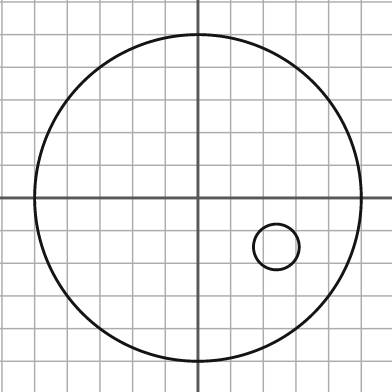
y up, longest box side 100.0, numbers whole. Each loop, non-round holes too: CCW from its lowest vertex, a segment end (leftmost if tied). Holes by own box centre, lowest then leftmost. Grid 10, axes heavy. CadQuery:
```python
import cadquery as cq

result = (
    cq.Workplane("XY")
    .moveTo(0.0, 0.0)
    .circle(50.0)
    .moveTo(24.0, -15.0)
    .circle(7.0)
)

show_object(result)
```